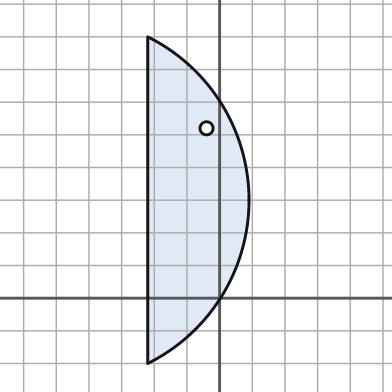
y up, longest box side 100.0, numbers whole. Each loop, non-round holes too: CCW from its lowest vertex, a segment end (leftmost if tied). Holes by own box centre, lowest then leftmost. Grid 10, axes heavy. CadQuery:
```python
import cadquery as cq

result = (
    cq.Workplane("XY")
    .moveTo(-22.0, -20.0)
    .threePointArc((9.0, 30.0), (-22.0, 80.0))
    .close()
    .moveTo(-4.0, 52.0)
    .circle(2.0)
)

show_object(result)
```